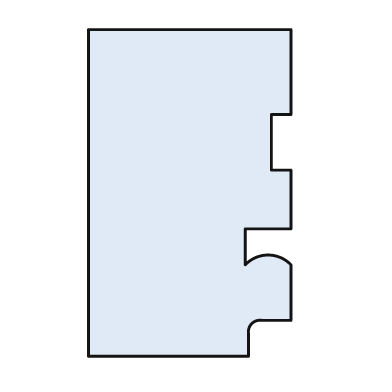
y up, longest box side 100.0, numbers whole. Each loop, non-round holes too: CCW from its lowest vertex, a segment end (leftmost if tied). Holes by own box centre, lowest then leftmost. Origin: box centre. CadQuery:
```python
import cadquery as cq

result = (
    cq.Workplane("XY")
    .moveTo(-31.0, -50.0)
    .lineTo(18.0, -50.0)
    .lineTo(18.0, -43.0)
    .threePointArc((19.0, -40.0), (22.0, -39.0))
    .lineTo(31.0, -39.0)
    .lineTo(31.0, -22.0)
    .threePointArc((24.0, -19.0), (17.0, -22.0))
    .lineTo(17.0, -11.0)
    .lineTo(31.0, -11.0)
    .lineTo(31.0, 7.0)
    .lineTo(25.0, 7.0)
    .lineTo(25.0, 24.0)
    .lineTo(31.0, 24.0)
    .lineTo(31.0, 50.0)
    .lineTo(-31.0, 50.0)
    .close()
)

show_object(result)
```